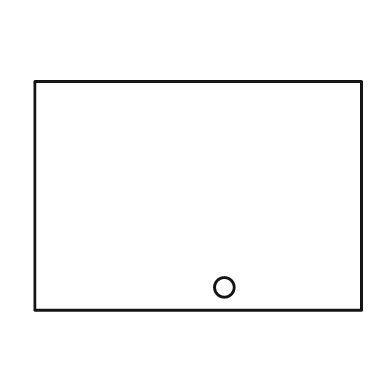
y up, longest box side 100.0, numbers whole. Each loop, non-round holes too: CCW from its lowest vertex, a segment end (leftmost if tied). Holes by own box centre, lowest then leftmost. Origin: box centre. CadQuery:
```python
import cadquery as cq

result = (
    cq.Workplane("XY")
    .moveTo(-50.0, -35.0)
    .lineTo(50.0, -35.0)
    .lineTo(50.0, 35.0)
    .lineTo(-50.0, 35.0)
    .close()
    .moveTo(8.0, -28.0)
    .circle(3.0)
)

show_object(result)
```